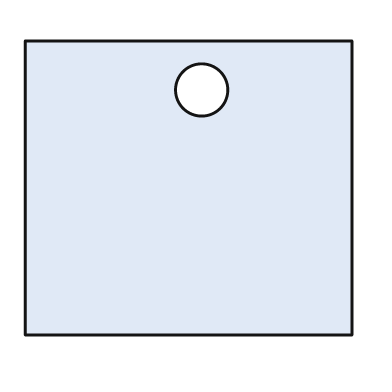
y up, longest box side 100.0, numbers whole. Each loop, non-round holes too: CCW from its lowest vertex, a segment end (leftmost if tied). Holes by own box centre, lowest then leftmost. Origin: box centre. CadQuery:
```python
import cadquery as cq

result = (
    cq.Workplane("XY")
    .moveTo(-50.0, -45.0)
    .lineTo(50.0, -45.0)
    .lineTo(50.0, 45.0)
    .lineTo(-50.0, 45.0)
    .close()
    .moveTo(4.0, 30.0)
    .circle(8.0)
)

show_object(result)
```